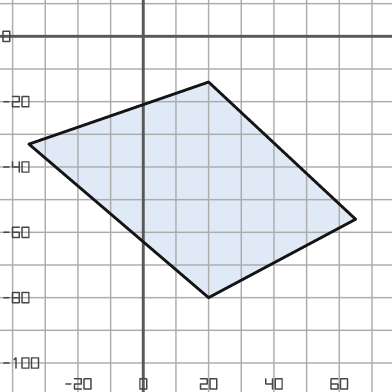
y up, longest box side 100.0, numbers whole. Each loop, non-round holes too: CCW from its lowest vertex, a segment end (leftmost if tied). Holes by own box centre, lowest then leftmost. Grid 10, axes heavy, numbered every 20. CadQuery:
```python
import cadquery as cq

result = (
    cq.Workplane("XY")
    .moveTo(20.0, -80.0)
    .lineTo(65.0, -56.0)
    .lineTo(20.0, -14.0)
    .lineTo(-35.0, -33.0)
    .close()
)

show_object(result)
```